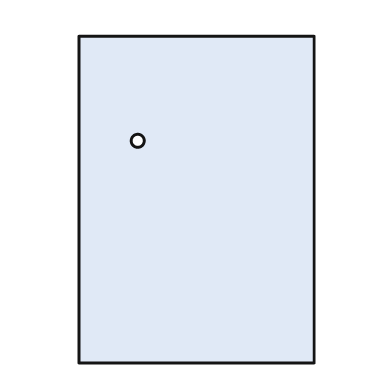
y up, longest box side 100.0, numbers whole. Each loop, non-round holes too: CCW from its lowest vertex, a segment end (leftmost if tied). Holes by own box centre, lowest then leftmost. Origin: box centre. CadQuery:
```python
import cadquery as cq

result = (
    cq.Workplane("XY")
    .moveTo(-36.0, -50.0)
    .lineTo(36.0, -50.0)
    .lineTo(36.0, 50.0)
    .lineTo(-36.0, 50.0)
    .close()
    .moveTo(-18.0, 18.0)
    .circle(2.0)
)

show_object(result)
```